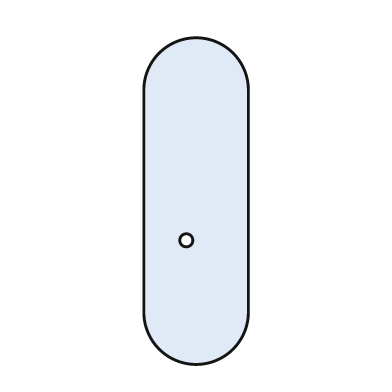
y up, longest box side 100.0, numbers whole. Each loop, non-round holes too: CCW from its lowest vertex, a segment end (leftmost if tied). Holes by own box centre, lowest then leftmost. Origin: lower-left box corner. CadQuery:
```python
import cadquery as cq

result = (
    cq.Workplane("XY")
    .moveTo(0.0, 16.0)
    .threePointArc((16.0, 0.0), (32.0, 16.0))
    .lineTo(32.0, 84.0)
    .threePointArc((16.0, 100.0), (0.0, 84.0))
    .close()
    .moveTo(13.0, 38.0)
    .circle(2.0)
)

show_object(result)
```